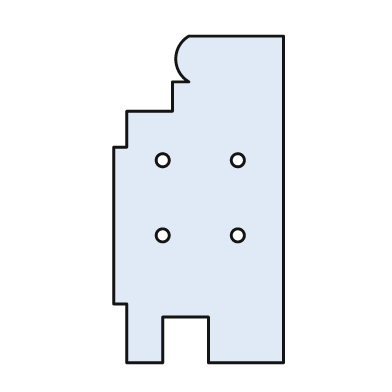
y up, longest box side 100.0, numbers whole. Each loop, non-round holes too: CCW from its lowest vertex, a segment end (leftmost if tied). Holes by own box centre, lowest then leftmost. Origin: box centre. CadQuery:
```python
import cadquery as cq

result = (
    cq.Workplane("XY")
    .moveTo(-22.0, -50.0)
    .lineTo(-11.0, -50.0)
    .lineTo(-11.0, -36.0)
    .lineTo(3.0, -36.0)
    .lineTo(3.0, -50.0)
    .lineTo(26.0, -50.0)
    .lineTo(26.0, 50.0)
    .lineTo(-3.0, 50.0)
    .threePointArc((-7.0, 43.0), (-3.0, 36.0))
    .lineTo(-8.0, 36.0)
    .lineTo(-8.0, 27.0)
    .lineTo(-22.0, 27.0)
    .lineTo(-22.0, 16.0)
    .lineTo(-26.0, 16.0)
    .lineTo(-26.0, -32.0)
    .lineTo(-22.0, -32.0)
    .close()
    .moveTo(-11.0, -11.0)
    .circle(2.0)
    .moveTo(12.0, -11.0)
    .circle(2.0)
    .moveTo(-11.0, 12.0)
    .circle(2.0)
    .moveTo(12.0, 12.0)
    .circle(2.0)
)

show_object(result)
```